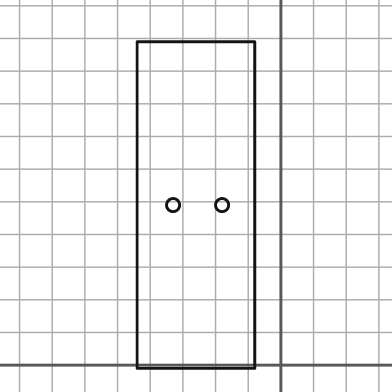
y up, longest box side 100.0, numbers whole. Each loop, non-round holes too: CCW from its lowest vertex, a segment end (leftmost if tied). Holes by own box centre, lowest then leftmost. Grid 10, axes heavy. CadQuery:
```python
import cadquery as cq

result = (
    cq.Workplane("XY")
    .moveTo(-44.0, -1.0)
    .lineTo(-8.0, -1.0)
    .lineTo(-8.0, 99.0)
    .lineTo(-44.0, 99.0)
    .close()
    .moveTo(-33.0, 49.0)
    .circle(2.0)
    .moveTo(-18.0, 49.0)
    .circle(2.0)
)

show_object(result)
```